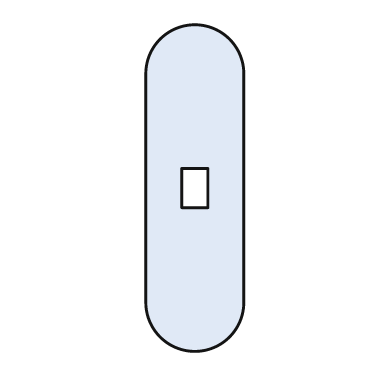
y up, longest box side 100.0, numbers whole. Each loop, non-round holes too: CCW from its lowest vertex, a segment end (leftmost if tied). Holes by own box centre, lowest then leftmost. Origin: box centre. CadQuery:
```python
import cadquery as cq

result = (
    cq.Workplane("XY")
    .moveTo(-15.0, -35.0)
    .threePointArc((0.0, -50.0), (15.0, -35.0))
    .lineTo(15.0, 35.0)
    .threePointArc((0.0, 50.0), (-15.0, 35.0))
    .close()
    .moveTo(-4.0, -6.0)
    .lineTo(4.0, -6.0)
    .lineTo(4.0, 6.0)
    .lineTo(-4.0, 6.0)
    .close()
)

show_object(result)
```